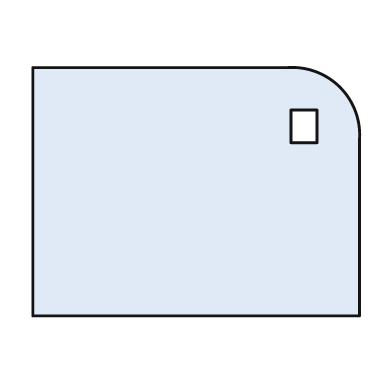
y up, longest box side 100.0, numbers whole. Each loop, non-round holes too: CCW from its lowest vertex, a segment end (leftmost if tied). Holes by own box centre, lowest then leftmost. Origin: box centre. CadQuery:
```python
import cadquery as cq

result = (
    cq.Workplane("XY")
    .moveTo(-50.0, -38.0)
    .lineTo(50.0, -38.0)
    .lineTo(50.0, 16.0)
    .threePointArc((44.0, 32.0), (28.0, 38.0))
    .lineTo(-50.0, 38.0)
    .close()
    .moveTo(29.0, 15.0)
    .lineTo(37.0, 15.0)
    .lineTo(37.0, 25.0)
    .lineTo(29.0, 25.0)
    .close()
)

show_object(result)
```